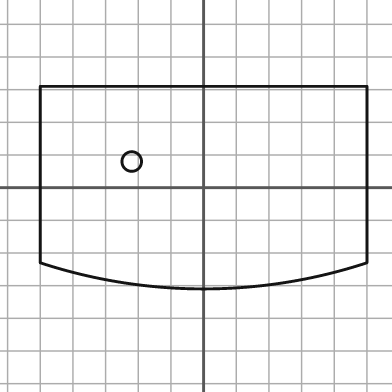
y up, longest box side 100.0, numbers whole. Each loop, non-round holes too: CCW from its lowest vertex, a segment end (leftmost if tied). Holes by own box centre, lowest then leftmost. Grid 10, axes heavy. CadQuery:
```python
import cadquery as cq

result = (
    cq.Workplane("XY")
    .moveTo(-50.0, -23.0)
    .threePointArc((0.0, -31.0), (50.0, -23.0))
    .lineTo(50.0, 31.0)
    .lineTo(-50.0, 31.0)
    .close()
    .moveTo(-22.0, 8.0)
    .circle(3.0)
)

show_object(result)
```